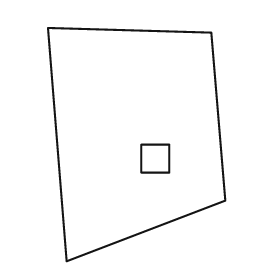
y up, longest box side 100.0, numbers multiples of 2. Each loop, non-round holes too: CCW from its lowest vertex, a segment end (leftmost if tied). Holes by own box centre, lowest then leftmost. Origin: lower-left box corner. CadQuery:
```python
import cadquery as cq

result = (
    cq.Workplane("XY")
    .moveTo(8.0, 0.0)
    .lineTo(76.0, 26.0)
    .lineTo(70.0, 98.0)
    .lineTo(0.0, 100.0)
    .close()
    .moveTo(40.0, 38.0)
    .lineTo(52.0, 38.0)
    .lineTo(52.0, 50.0)
    .lineTo(40.0, 50.0)
    .close()
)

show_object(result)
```